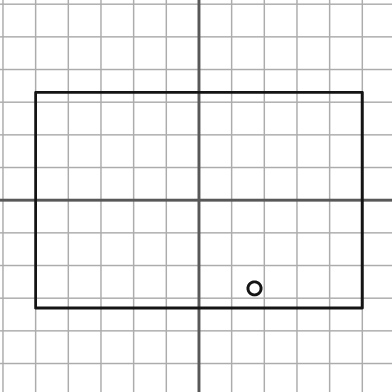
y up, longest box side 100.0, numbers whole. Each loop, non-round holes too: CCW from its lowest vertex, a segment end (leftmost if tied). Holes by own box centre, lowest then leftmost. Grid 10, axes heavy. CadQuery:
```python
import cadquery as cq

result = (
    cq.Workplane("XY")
    .moveTo(-50.0, -33.0)
    .lineTo(50.0, -33.0)
    .lineTo(50.0, 33.0)
    .lineTo(-50.0, 33.0)
    .close()
    .moveTo(17.0, -27.0)
    .circle(2.0)
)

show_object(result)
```